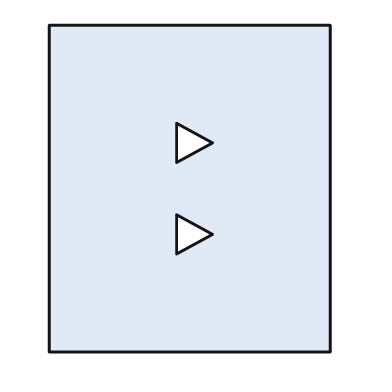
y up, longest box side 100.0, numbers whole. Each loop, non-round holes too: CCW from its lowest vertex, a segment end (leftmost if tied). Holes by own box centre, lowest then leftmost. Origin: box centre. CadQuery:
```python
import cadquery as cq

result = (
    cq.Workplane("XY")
    .moveTo(-43.0, -50.0)
    .lineTo(43.0, -50.0)
    .lineTo(43.0, 50.0)
    .lineTo(-43.0, 50.0)
    .close()
    .moveTo(-4.0, -20.0)
    .lineTo(7.0, -14.0)
    .lineTo(-4.0, -8.0)
    .close()
    .moveTo(-4.0, 8.0)
    .lineTo(7.0, 14.0)
    .lineTo(-4.0, 20.0)
    .close()
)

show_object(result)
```